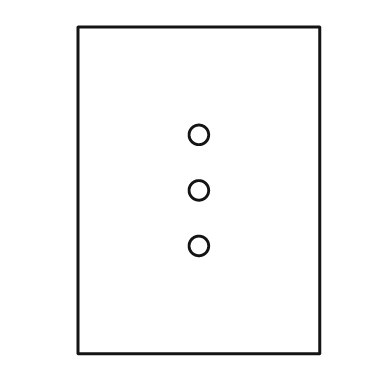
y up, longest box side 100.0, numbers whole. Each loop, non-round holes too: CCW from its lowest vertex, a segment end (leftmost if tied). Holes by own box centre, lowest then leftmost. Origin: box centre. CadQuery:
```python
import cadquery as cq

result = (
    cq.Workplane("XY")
    .moveTo(-37.0, -50.0)
    .lineTo(37.0, -50.0)
    .lineTo(37.0, 50.0)
    .lineTo(-37.0, 50.0)
    .close()
    .moveTo(0.0, -17.0)
    .circle(3.0)
    .moveTo(0.0, 0.0)
    .circle(3.0)
    .moveTo(0.0, 17.0)
    .circle(3.0)
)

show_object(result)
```